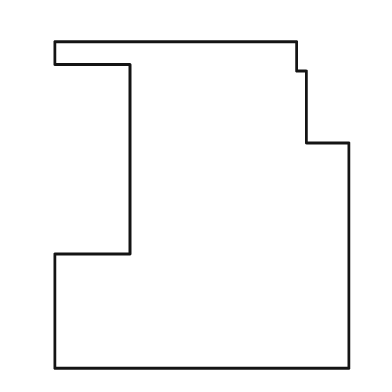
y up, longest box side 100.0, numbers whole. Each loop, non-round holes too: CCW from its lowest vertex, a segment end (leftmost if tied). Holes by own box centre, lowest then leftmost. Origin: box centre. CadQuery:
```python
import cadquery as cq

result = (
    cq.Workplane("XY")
    .moveTo(-45.0, -50.0)
    .lineTo(45.0, -50.0)
    .lineTo(45.0, 19.0)
    .lineTo(32.0, 19.0)
    .lineTo(32.0, 41.0)
    .lineTo(29.0, 41.0)
    .lineTo(29.0, 50.0)
    .lineTo(-45.0, 50.0)
    .lineTo(-45.0, 43.0)
    .lineTo(-22.0, 43.0)
    .lineTo(-22.0, -15.0)
    .lineTo(-45.0, -15.0)
    .close()
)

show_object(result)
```